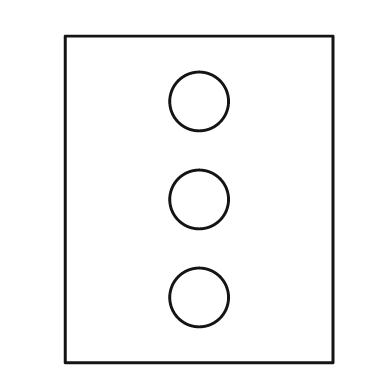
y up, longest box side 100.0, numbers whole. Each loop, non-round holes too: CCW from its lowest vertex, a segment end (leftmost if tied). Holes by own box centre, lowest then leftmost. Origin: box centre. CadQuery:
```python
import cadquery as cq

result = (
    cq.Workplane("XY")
    .moveTo(-41.0, -50.0)
    .lineTo(41.0, -50.0)
    .lineTo(41.0, 50.0)
    .lineTo(-41.0, 50.0)
    .close()
    .moveTo(0.0, -30.0)
    .circle(9.0)
    .moveTo(0.0, 0.0)
    .circle(9.0)
    .moveTo(0.0, 30.0)
    .circle(9.0)
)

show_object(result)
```